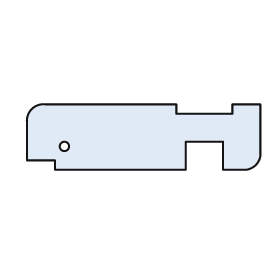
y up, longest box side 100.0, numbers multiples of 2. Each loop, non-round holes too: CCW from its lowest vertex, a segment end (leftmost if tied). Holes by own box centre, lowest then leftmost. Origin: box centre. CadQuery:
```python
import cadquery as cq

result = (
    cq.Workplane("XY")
    .moveTo(-38.0, -14.0)
    .lineTo(18.0, -14.0)
    .lineTo(18.0, -2.0)
    .lineTo(34.0, -2.0)
    .lineTo(34.0, -14.0)
    .lineTo(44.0, -14.0)
    .threePointArc((48.0, -12.0), (50.0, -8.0))
    .lineTo(50.0, 14.0)
    .lineTo(38.0, 14.0)
    .lineTo(38.0, 10.0)
    .lineTo(14.0, 10.0)
    .lineTo(14.0, 14.0)
    .lineTo(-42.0, 14.0)
    .threePointArc((-48.0, 12.0), (-50.0, 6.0))
    .lineTo(-50.0, -10.0)
    .lineTo(-38.0, -10.0)
    .close()
    .moveTo(-34.0, -4.0)
    .circle(2.0)
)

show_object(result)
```